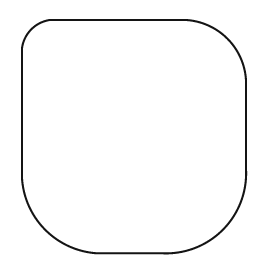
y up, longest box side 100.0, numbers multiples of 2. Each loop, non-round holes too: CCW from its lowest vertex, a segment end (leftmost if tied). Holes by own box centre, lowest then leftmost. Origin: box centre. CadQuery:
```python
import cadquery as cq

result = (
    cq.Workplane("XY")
    .moveTo(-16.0, -50.0)
    .lineTo(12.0, -50.0)
    .threePointArc((38.0, -40.0), (48.0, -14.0))
    .lineTo(48.0, 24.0)
    .threePointArc((40.0, 42.0), (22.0, 50.0))
    .lineTo(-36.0, 50.0)
    .threePointArc((-44.0, 46.0), (-48.0, 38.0))
    .lineTo(-48.0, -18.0)
    .threePointArc((-38.0, -40.0), (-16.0, -50.0))
    .close()
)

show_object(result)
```